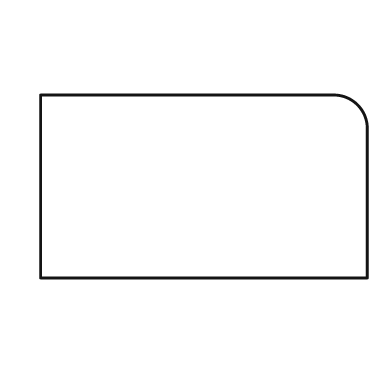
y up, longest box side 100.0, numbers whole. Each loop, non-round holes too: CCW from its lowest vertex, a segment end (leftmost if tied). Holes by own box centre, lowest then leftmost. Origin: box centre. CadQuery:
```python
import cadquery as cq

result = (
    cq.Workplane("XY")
    .moveTo(-50.0, -28.0)
    .lineTo(50.0, -28.0)
    .lineTo(50.0, 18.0)
    .threePointArc((47.0, 25.0), (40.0, 28.0))
    .lineTo(-50.0, 28.0)
    .close()
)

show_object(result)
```